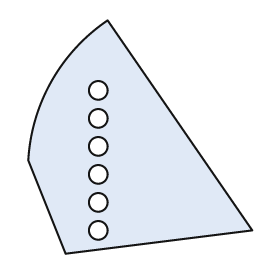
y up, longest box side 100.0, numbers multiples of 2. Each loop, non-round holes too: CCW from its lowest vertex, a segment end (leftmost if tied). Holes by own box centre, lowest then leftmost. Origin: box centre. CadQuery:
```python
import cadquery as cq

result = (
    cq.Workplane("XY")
    .moveTo(-32.0, -50.0)
    .lineTo(48.0, -40.0)
    .lineTo(-14.0, 50.0)
    .threePointArc((-38.0, 24.0), (-48.0, -10.0))
    .close()
    .moveTo(-18.0, -40.0)
    .circle(4.0)
    .moveTo(-18.0, -28.0)
    .circle(4.0)
    .moveTo(-18.0, -16.0)
    .circle(4.0)
    .moveTo(-18.0, -4.0)
    .circle(4.0)
    .moveTo(-18.0, 8.0)
    .circle(4.0)
    .moveTo(-18.0, 20.0)
    .circle(4.0)
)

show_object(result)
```